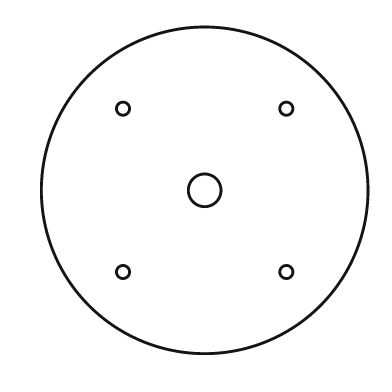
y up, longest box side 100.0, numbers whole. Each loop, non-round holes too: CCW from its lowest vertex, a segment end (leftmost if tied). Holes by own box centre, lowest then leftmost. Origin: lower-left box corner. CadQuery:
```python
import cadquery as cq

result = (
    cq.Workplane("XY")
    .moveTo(50.0, 50.0)
    .circle(50.0)
    .moveTo(25.0, 25.0)
    .circle(2.0)
    .moveTo(75.0, 25.0)
    .circle(2.0)
    .moveTo(50.0, 50.0)
    .circle(5.0)
    .moveTo(25.0, 75.0)
    .circle(2.0)
    .moveTo(75.0, 75.0)
    .circle(2.0)
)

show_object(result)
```